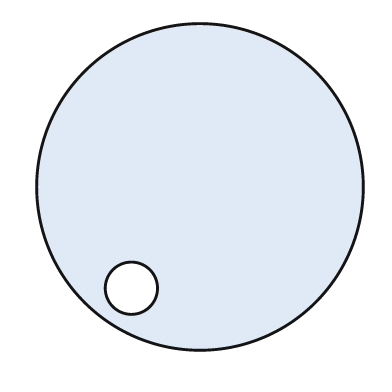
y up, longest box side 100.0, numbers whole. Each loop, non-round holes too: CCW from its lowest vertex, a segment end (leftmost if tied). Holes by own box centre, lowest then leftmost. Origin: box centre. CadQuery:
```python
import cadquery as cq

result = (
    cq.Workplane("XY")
    .moveTo(0.0, 0.0)
    .circle(50.0)
    .moveTo(-21.0, -31.0)
    .circle(8.0)
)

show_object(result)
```